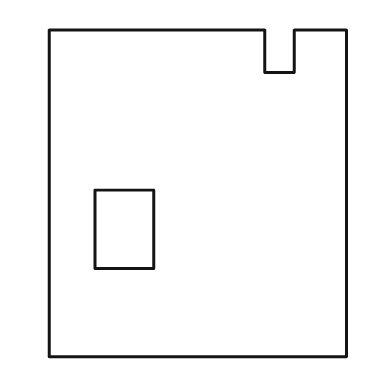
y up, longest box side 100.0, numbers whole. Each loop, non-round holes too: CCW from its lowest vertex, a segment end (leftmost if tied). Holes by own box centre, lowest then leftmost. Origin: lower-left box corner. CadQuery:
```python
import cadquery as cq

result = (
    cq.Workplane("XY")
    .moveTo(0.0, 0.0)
    .lineTo(91.0, 0.0)
    .lineTo(91.0, 100.0)
    .lineTo(75.0, 100.0)
    .lineTo(75.0, 87.0)
    .lineTo(66.0, 87.0)
    .lineTo(66.0, 100.0)
    .lineTo(0.0, 100.0)
    .close()
    .moveTo(14.0, 27.0)
    .lineTo(32.0, 27.0)
    .lineTo(32.0, 51.0)
    .lineTo(14.0, 51.0)
    .close()
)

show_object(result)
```